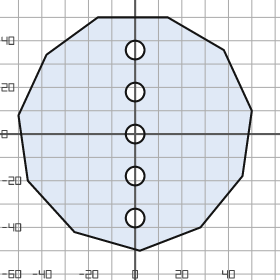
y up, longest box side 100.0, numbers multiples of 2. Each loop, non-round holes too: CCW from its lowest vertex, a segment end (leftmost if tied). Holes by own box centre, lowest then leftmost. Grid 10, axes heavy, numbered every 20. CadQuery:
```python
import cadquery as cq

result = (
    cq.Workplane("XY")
    .moveTo(2.0, -50.0)
    .lineTo(28.0, -40.0)
    .lineTo(46.0, -18.0)
    .lineTo(50.0, 10.0)
    .lineTo(38.0, 36.0)
    .lineTo(14.0, 50.0)
    .lineTo(-16.0, 50.0)
    .lineTo(-38.0, 34.0)
    .lineTo(-50.0, 8.0)
    .lineTo(-46.0, -20.0)
    .lineTo(-26.0, -42.0)
    .close()
    .moveTo(0.0, -36.0)
    .circle(4.0)
    .moveTo(0.0, -18.0)
    .circle(4.0)
    .moveTo(0.0, 0.0)
    .circle(4.0)
    .moveTo(0.0, 18.0)
    .circle(4.0)
    .moveTo(0.0, 36.0)
    .circle(4.0)
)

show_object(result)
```